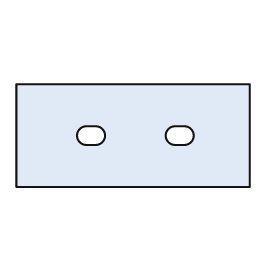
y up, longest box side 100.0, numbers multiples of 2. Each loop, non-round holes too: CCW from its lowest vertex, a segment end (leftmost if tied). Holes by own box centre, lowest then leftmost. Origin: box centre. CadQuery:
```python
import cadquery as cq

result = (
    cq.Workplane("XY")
    .moveTo(-50.0, -22.0)
    .lineTo(50.0, -22.0)
    .lineTo(50.0, 22.0)
    .lineTo(-50.0, 22.0)
    .close()
    .moveTo(-20.0, -4.0)
    .lineTo(-16.0, -4.0)
    .threePointArc((-12.0, 0.0), (-16.0, 4.0))
    .lineTo(-20.0, 4.0)
    .threePointArc((-24.0, 0.0), (-20.0, -4.0))
    .close()
    .moveTo(18.0, -4.0)
    .lineTo(22.0, -4.0)
    .threePointArc((26.0, 0.0), (22.0, 4.0))
    .lineTo(18.0, 4.0)
    .threePointArc((14.0, 0.0), (18.0, -4.0))
    .close()
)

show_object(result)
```